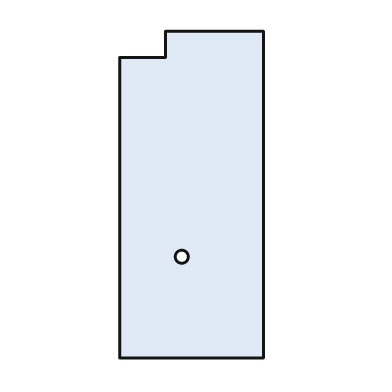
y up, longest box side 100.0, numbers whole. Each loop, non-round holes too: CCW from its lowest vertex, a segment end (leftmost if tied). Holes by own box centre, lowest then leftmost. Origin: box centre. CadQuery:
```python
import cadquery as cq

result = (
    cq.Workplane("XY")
    .moveTo(-22.0, -50.0)
    .lineTo(22.0, -50.0)
    .lineTo(22.0, 50.0)
    .lineTo(-8.0, 50.0)
    .lineTo(-8.0, 42.0)
    .lineTo(-22.0, 42.0)
    .close()
    .moveTo(-3.0, -19.0)
    .circle(2.0)
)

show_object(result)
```